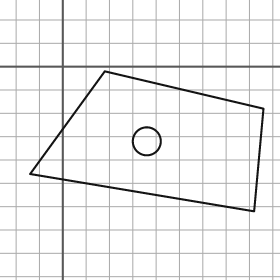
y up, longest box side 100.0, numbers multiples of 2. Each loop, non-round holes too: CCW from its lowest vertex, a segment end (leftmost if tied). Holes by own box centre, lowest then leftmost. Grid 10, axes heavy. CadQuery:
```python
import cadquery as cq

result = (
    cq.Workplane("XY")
    .moveTo(82.0, -62.0)
    .lineTo(86.0, -18.0)
    .lineTo(18.0, -2.0)
    .lineTo(-14.0, -46.0)
    .close()
    .moveTo(36.0, -32.0)
    .circle(6.0)
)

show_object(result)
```